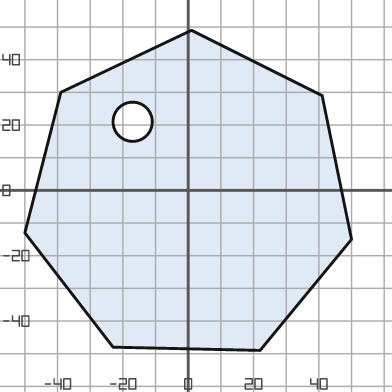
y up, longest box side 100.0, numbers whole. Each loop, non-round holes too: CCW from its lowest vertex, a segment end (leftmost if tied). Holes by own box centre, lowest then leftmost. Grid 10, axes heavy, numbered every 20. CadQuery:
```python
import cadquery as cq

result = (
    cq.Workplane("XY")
    .moveTo(22.0, -49.0)
    .lineTo(50.0, -15.0)
    .lineTo(41.0, 29.0)
    .lineTo(1.0, 49.0)
    .lineTo(-39.0, 30.0)
    .lineTo(-50.0, -13.0)
    .lineTo(-23.0, -48.0)
    .close()
    .moveTo(-17.0, 21.0)
    .circle(6.0)
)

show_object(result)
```